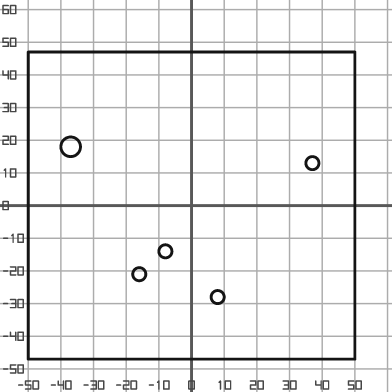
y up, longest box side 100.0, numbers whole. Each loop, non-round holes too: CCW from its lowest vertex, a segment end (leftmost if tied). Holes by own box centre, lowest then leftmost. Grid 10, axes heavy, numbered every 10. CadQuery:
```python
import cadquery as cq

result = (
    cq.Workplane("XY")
    .moveTo(-50.0, -47.0)
    .lineTo(50.0, -47.0)
    .lineTo(50.0, 47.0)
    .lineTo(-50.0, 47.0)
    .close()
    .moveTo(8.0, -28.0)
    .circle(2.0)
    .moveTo(-16.0, -21.0)
    .circle(2.0)
    .moveTo(-8.0, -14.0)
    .circle(2.0)
    .moveTo(37.0, 13.0)
    .circle(2.0)
    .moveTo(-37.0, 18.0)
    .circle(3.0)
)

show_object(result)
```